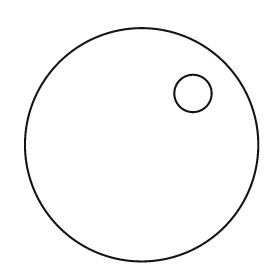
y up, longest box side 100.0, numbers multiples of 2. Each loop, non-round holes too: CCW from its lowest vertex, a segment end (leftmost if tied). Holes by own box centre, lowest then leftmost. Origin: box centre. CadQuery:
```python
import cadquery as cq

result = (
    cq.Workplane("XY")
    .moveTo(0.0, 0.0)
    .circle(50.0)
    .moveTo(22.0, 22.0)
    .circle(8.0)
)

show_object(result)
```